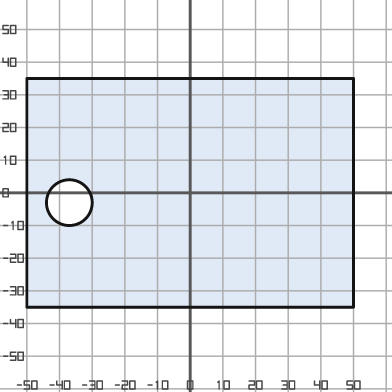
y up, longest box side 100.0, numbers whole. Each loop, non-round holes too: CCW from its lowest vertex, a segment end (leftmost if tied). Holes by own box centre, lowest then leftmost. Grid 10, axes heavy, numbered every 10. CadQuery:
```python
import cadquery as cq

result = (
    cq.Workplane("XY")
    .moveTo(-50.0, -35.0)
    .lineTo(50.0, -35.0)
    .lineTo(50.0, 35.0)
    .lineTo(-50.0, 35.0)
    .close()
    .moveTo(-37.0, -3.0)
    .circle(7.0)
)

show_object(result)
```